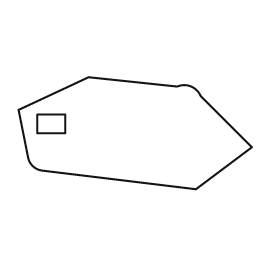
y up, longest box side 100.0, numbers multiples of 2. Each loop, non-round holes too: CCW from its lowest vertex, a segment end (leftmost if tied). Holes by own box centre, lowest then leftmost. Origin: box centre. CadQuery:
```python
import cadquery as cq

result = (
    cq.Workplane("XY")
    .moveTo(26.0, -24.0)
    .lineTo(50.0, -6.0)
    .lineTo(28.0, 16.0)
    .threePointArc((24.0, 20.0), (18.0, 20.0))
    .lineTo(-20.0, 24.0)
    .lineTo(-50.0, 10.0)
    .lineTo(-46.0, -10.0)
    .threePointArc((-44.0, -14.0), (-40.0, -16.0))
    .close()
    .moveTo(-42.0, 0.0)
    .lineTo(-30.0, 0.0)
    .lineTo(-30.0, 8.0)
    .lineTo(-42.0, 8.0)
    .close()
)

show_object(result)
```